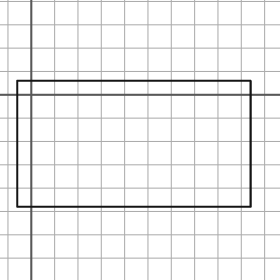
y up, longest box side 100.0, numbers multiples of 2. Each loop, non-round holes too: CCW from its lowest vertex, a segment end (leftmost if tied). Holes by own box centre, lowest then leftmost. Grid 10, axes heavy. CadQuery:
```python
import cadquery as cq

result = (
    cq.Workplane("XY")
    .moveTo(-6.0, -48.0)
    .lineTo(94.0, -48.0)
    .lineTo(94.0, 6.0)
    .lineTo(-6.0, 6.0)
    .close()
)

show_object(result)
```